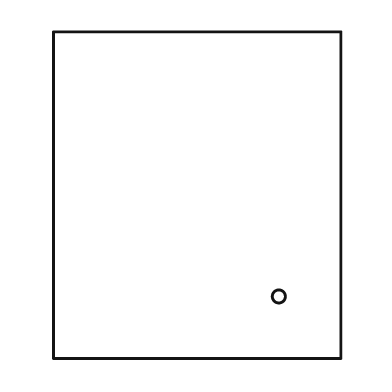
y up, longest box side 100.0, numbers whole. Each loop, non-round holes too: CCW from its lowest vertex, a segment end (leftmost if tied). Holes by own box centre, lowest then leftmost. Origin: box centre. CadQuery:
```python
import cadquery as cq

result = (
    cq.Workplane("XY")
    .moveTo(-44.0, -50.0)
    .lineTo(44.0, -50.0)
    .lineTo(44.0, 50.0)
    .lineTo(-44.0, 50.0)
    .close()
    .moveTo(25.0, -31.0)
    .circle(2.0)
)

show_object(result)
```